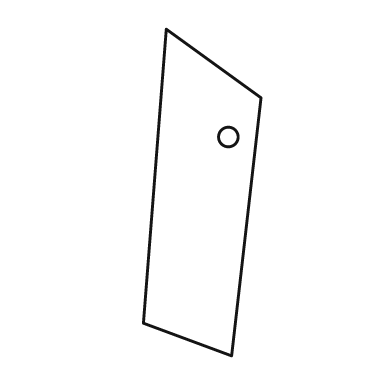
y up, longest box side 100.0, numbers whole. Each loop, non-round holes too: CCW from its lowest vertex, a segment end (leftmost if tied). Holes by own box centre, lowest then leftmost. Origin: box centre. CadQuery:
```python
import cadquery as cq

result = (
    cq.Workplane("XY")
    .moveTo(9.0, -50.0)
    .lineTo(18.0, 29.0)
    .lineTo(-11.0, 50.0)
    .lineTo(-18.0, -40.0)
    .close()
    .moveTo(8.0, 17.0)
    .circle(3.0)
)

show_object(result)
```